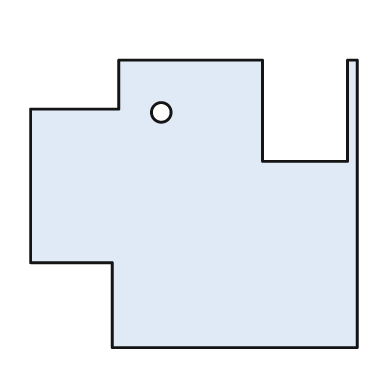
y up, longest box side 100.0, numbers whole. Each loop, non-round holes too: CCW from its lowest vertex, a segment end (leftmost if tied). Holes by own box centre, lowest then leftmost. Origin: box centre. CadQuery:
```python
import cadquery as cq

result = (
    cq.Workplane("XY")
    .moveTo(-25.0, -44.0)
    .lineTo(50.0, -44.0)
    .lineTo(50.0, 44.0)
    .lineTo(47.0, 44.0)
    .lineTo(47.0, 13.0)
    .lineTo(21.0, 13.0)
    .lineTo(21.0, 44.0)
    .lineTo(-23.0, 44.0)
    .lineTo(-23.0, 29.0)
    .lineTo(-50.0, 29.0)
    .lineTo(-50.0, -18.0)
    .lineTo(-25.0, -18.0)
    .close()
    .moveTo(-10.0, 28.0)
    .circle(3.0)
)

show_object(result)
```